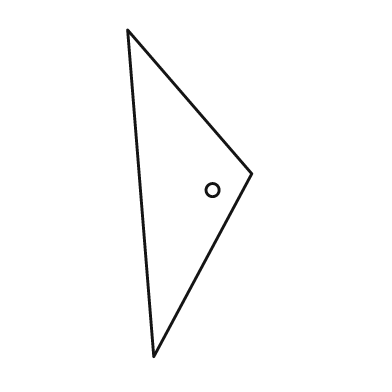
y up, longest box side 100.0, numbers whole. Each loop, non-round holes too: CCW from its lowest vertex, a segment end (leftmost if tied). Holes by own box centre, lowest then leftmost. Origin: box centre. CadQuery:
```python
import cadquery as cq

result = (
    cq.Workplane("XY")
    .moveTo(-11.0, -50.0)
    .lineTo(19.0, 6.0)
    .lineTo(-19.0, 50.0)
    .close()
    .moveTo(7.0, 1.0)
    .circle(2.0)
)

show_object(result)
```